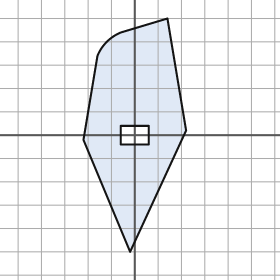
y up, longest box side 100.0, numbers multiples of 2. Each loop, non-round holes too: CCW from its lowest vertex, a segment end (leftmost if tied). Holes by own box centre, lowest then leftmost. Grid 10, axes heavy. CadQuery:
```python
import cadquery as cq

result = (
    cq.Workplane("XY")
    .moveTo(-2.0, -50.0)
    .lineTo(22.0, 2.0)
    .lineTo(14.0, 50.0)
    .lineTo(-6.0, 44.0)
    .threePointArc((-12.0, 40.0), (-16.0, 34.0))
    .lineTo(-22.0, -2.0)
    .close()
    .moveTo(-6.0, -4.0)
    .lineTo(6.0, -4.0)
    .lineTo(6.0, 4.0)
    .lineTo(-6.0, 4.0)
    .close()
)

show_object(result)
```